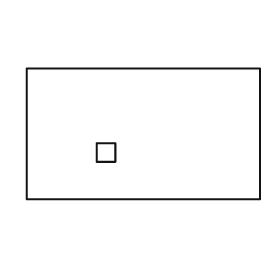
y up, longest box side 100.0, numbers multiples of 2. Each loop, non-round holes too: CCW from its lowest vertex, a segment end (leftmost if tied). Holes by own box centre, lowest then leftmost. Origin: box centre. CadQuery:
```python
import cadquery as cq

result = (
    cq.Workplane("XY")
    .moveTo(-50.0, -28.0)
    .lineTo(50.0, -28.0)
    .lineTo(50.0, 28.0)
    .lineTo(-50.0, 28.0)
    .close()
    .moveTo(-20.0, -12.0)
    .lineTo(-12.0, -12.0)
    .lineTo(-12.0, -4.0)
    .lineTo(-20.0, -4.0)
    .close()
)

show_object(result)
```